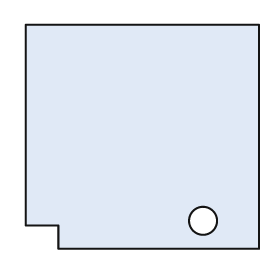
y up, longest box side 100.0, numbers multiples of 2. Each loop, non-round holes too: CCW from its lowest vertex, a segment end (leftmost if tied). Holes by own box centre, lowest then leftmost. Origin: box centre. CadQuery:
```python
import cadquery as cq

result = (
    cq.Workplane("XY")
    .moveTo(-36.0, -48.0)
    .lineTo(50.0, -48.0)
    .lineTo(50.0, 48.0)
    .lineTo(-50.0, 48.0)
    .lineTo(-50.0, -38.0)
    .lineTo(-36.0, -38.0)
    .close()
    .moveTo(26.0, -36.0)
    .circle(6.0)
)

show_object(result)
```